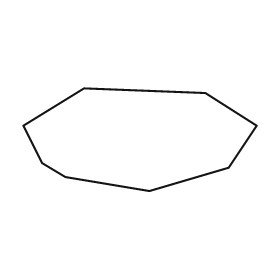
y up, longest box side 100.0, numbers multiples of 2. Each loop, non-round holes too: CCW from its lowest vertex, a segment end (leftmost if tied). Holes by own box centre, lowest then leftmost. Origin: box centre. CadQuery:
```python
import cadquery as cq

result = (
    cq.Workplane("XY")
    .moveTo(4.0, -22.0)
    .lineTo(38.0, -12.0)
    .lineTo(50.0, 6.0)
    .lineTo(28.0, 20.0)
    .lineTo(-24.0, 22.0)
    .lineTo(-50.0, 6.0)
    .lineTo(-42.0, -10.0)
    .lineTo(-32.0, -16.0)
    .close()
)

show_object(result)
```